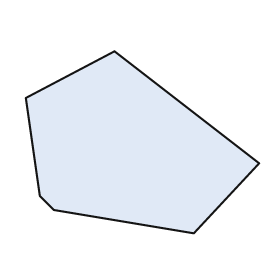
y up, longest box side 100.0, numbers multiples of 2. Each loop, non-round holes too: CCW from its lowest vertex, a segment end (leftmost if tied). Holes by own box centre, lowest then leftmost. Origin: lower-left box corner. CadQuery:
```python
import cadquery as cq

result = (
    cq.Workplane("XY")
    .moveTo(72.0, 0.0)
    .lineTo(100.0, 30.0)
    .lineTo(38.0, 78.0)
    .lineTo(0.0, 58.0)
    .lineTo(6.0, 16.0)
    .lineTo(12.0, 10.0)
    .close()
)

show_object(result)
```